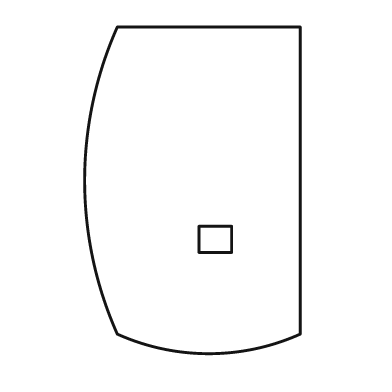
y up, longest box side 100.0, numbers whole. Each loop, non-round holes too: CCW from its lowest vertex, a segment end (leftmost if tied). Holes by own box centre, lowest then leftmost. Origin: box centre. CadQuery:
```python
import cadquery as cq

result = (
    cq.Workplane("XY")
    .moveTo(-23.0, -44.0)
    .threePointArc((5.0, -50.0), (33.0, -44.0))
    .lineTo(33.0, 50.0)
    .lineTo(-23.0, 50.0)
    .threePointArc((-33.0, 3.0), (-23.0, -44.0))
    .close()
    .moveTo(2.0, -19.0)
    .lineTo(12.0, -19.0)
    .lineTo(12.0, -11.0)
    .lineTo(2.0, -11.0)
    .close()
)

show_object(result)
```